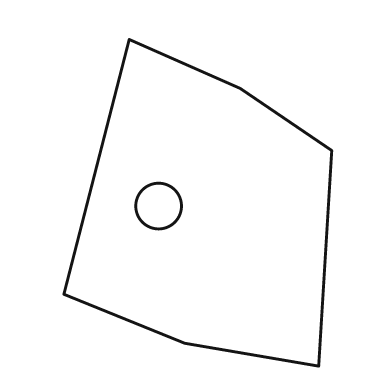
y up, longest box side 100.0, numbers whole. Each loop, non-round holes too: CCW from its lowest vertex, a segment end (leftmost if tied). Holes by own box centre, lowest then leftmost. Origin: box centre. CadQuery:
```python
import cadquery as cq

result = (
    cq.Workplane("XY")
    .moveTo(37.0, -50.0)
    .lineTo(41.0, 16.0)
    .lineTo(13.0, 35.0)
    .lineTo(-21.0, 50.0)
    .lineTo(-41.0, -28.0)
    .lineTo(-4.0, -43.0)
    .close()
    .moveTo(-12.0, -1.0)
    .circle(7.0)
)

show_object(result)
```